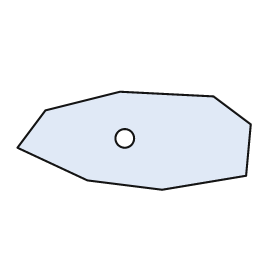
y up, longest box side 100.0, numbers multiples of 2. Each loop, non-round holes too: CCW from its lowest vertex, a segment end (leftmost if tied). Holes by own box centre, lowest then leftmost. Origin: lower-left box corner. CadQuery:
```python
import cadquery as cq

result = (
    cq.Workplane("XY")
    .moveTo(62.0, 0.0)
    .lineTo(98.0, 6.0)
    .lineTo(100.0, 28.0)
    .lineTo(84.0, 40.0)
    .lineTo(44.0, 42.0)
    .lineTo(12.0, 34.0)
    .lineTo(0.0, 18.0)
    .lineTo(30.0, 4.0)
    .close()
    .moveTo(46.0, 22.0)
    .circle(4.0)
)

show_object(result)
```